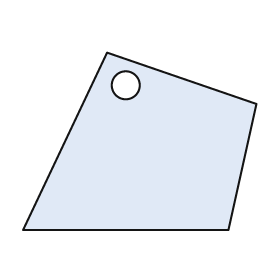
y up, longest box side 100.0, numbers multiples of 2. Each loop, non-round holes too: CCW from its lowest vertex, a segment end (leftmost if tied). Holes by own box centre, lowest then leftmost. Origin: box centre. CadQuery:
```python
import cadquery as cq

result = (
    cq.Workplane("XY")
    .moveTo(-50.0, -38.0)
    .lineTo(38.0, -38.0)
    .lineTo(50.0, 16.0)
    .lineTo(-14.0, 38.0)
    .close()
    .moveTo(-6.0, 24.0)
    .circle(6.0)
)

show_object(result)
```